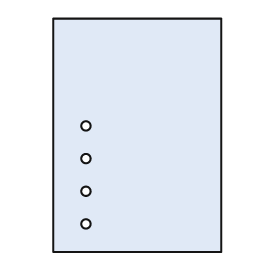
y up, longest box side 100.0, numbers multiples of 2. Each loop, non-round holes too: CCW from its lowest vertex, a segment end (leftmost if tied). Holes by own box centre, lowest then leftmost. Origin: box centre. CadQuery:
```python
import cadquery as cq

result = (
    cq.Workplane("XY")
    .moveTo(-36.0, -50.0)
    .lineTo(36.0, -50.0)
    .lineTo(36.0, 50.0)
    .lineTo(-36.0, 50.0)
    .close()
    .moveTo(-22.0, -38.0)
    .circle(2.0)
    .moveTo(-22.0, -24.0)
    .circle(2.0)
    .moveTo(-22.0, -10.0)
    .circle(2.0)
    .moveTo(-22.0, 4.0)
    .circle(2.0)
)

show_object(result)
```